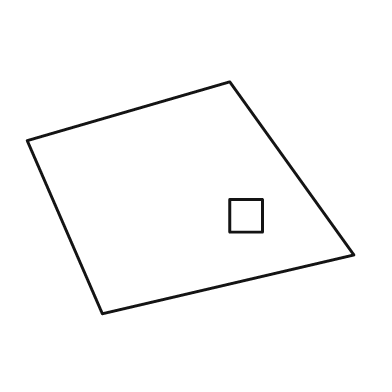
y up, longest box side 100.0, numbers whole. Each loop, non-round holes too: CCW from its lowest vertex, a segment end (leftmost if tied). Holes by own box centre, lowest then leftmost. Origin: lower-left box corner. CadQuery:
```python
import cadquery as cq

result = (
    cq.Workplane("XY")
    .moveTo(23.0, 0.0)
    .lineTo(100.0, 18.0)
    .lineTo(62.0, 71.0)
    .lineTo(0.0, 53.0)
    .close()
    .moveTo(62.0, 25.0)
    .lineTo(72.0, 25.0)
    .lineTo(72.0, 35.0)
    .lineTo(62.0, 35.0)
    .close()
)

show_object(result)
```